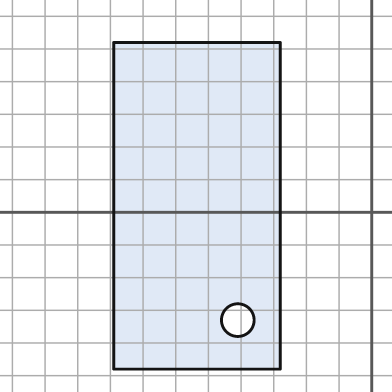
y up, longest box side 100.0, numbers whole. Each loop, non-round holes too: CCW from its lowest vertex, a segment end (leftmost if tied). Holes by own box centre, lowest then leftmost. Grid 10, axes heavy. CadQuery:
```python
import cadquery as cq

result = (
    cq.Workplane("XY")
    .moveTo(-79.0, -48.0)
    .lineTo(-28.0, -48.0)
    .lineTo(-28.0, 52.0)
    .lineTo(-79.0, 52.0)
    .close()
    .moveTo(-41.0, -33.0)
    .circle(5.0)
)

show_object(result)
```